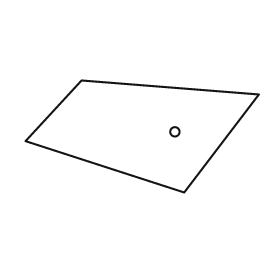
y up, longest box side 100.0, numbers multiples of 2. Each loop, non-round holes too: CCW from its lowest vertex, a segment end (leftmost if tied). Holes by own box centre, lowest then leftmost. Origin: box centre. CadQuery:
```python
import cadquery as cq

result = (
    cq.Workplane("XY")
    .moveTo(18.0, -24.0)
    .lineTo(50.0, 18.0)
    .lineTo(-26.0, 24.0)
    .lineTo(-50.0, -2.0)
    .close()
    .moveTo(14.0, 2.0)
    .circle(2.0)
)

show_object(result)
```